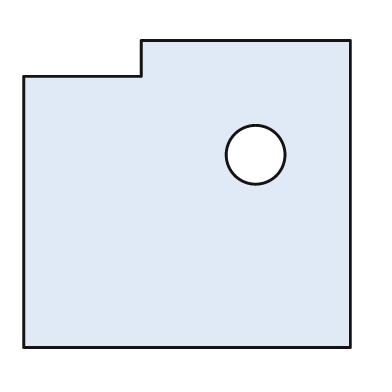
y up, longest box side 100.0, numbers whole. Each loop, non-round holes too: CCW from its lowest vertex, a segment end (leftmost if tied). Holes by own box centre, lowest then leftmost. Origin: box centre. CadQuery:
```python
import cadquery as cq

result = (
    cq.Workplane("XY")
    .moveTo(-50.0, -47.0)
    .lineTo(50.0, -47.0)
    .lineTo(50.0, 47.0)
    .lineTo(-14.0, 47.0)
    .lineTo(-14.0, 36.0)
    .lineTo(-50.0, 36.0)
    .close()
    .moveTo(21.0, 12.0)
    .circle(9.0)
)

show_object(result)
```